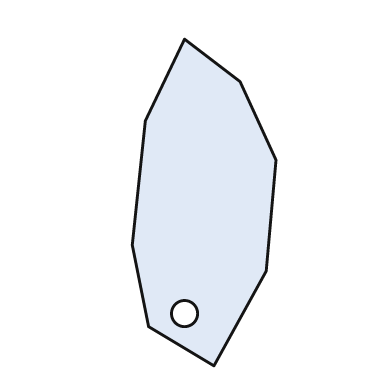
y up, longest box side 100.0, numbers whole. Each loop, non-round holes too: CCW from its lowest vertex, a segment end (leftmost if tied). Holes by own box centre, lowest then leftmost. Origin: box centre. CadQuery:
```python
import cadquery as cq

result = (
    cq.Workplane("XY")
    .moveTo(3.0, -50.0)
    .lineTo(19.0, -21.0)
    .lineTo(22.0, 13.0)
    .lineTo(11.0, 37.0)
    .lineTo(-6.0, 50.0)
    .lineTo(-18.0, 25.0)
    .lineTo(-22.0, -13.0)
    .lineTo(-17.0, -38.0)
    .close()
    .moveTo(-6.0, -34.0)
    .circle(4.0)
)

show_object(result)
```